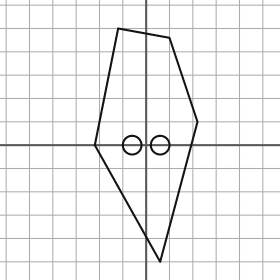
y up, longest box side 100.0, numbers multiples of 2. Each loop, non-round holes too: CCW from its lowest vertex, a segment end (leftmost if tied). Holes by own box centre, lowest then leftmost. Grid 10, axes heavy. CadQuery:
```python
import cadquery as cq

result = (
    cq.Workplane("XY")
    .moveTo(6.0, -50.0)
    .lineTo(22.0, 10.0)
    .lineTo(10.0, 46.0)
    .lineTo(-12.0, 50.0)
    .lineTo(-22.0, 0.0)
    .close()
    .moveTo(-6.0, 0.0)
    .circle(4.0)
    .moveTo(6.0, 0.0)
    .circle(4.0)
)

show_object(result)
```